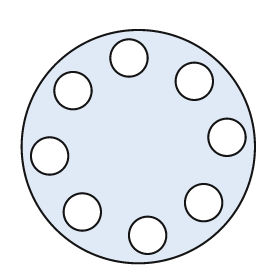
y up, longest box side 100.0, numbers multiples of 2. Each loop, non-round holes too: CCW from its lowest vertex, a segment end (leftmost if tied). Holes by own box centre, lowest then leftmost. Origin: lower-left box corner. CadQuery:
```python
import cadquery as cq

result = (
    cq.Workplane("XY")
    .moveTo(50.0, 50.0)
    .circle(50.0)
    .moveTo(54.0, 12.0)
    .circle(8.0)
    .moveTo(26.0, 22.0)
    .circle(8.0)
    .moveTo(78.0, 26.0)
    .circle(8.0)
    .moveTo(12.0, 46.0)
    .circle(8.0)
    .moveTo(88.0, 54.0)
    .circle(8.0)
    .moveTo(22.0, 74.0)
    .circle(8.0)
    .moveTo(74.0, 78.0)
    .circle(8.0)
    .moveTo(46.0, 88.0)
    .circle(8.0)
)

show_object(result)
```